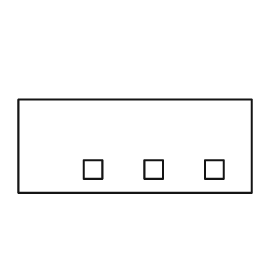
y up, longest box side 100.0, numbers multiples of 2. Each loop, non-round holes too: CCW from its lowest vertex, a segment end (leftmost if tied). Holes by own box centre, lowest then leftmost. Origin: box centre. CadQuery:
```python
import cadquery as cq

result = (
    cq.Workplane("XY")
    .moveTo(-50.0, -20.0)
    .lineTo(50.0, -20.0)
    .lineTo(50.0, 20.0)
    .lineTo(-50.0, 20.0)
    .close()
    .moveTo(-22.0, -14.0)
    .lineTo(-14.0, -14.0)
    .lineTo(-14.0, -6.0)
    .lineTo(-22.0, -6.0)
    .close()
    .moveTo(4.0, -14.0)
    .lineTo(12.0, -14.0)
    .lineTo(12.0, -6.0)
    .lineTo(4.0, -6.0)
    .close()
    .moveTo(30.0, -14.0)
    .lineTo(38.0, -14.0)
    .lineTo(38.0, -6.0)
    .lineTo(30.0, -6.0)
    .close()
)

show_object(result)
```